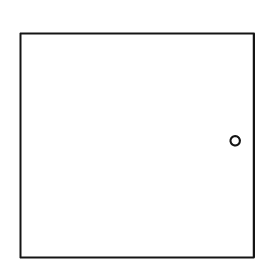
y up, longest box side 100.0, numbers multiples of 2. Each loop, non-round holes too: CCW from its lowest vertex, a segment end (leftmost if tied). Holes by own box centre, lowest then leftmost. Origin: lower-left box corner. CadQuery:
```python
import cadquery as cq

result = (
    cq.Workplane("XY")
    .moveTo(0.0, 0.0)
    .lineTo(100.0, 0.0)
    .lineTo(100.0, 96.0)
    .lineTo(0.0, 96.0)
    .close()
    .moveTo(92.0, 50.0)
    .circle(2.0)
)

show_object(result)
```